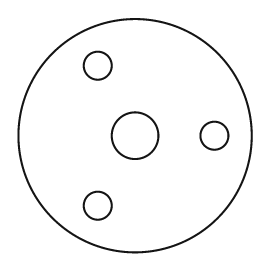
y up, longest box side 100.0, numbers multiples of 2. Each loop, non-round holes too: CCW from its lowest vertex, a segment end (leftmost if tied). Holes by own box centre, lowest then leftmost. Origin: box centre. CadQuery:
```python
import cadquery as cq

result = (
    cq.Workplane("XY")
    .moveTo(0.0, 0.0)
    .circle(50.0)
    .moveTo(-16.0, -30.0)
    .circle(6.0)
    .moveTo(0.0, 0.0)
    .circle(10.0)
    .moveTo(34.0, 0.0)
    .circle(6.0)
    .moveTo(-16.0, 30.0)
    .circle(6.0)
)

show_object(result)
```